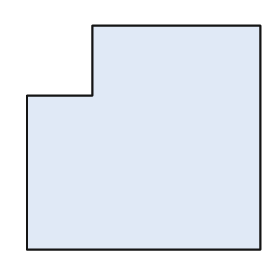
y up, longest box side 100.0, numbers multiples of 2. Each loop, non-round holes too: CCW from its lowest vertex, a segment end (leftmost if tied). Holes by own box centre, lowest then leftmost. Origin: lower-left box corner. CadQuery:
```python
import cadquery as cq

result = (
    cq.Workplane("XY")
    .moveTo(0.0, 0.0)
    .lineTo(100.0, 0.0)
    .lineTo(100.0, 96.0)
    .lineTo(28.0, 96.0)
    .lineTo(28.0, 66.0)
    .lineTo(0.0, 66.0)
    .close()
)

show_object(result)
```